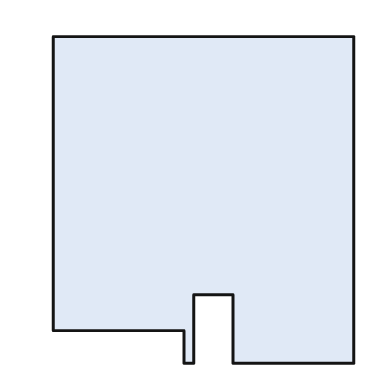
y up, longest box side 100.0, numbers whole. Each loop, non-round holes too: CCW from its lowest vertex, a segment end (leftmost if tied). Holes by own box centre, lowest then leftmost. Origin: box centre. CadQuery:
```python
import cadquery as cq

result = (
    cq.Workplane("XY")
    .moveTo(-6.0, -50.0)
    .lineTo(-3.0, -50.0)
    .lineTo(-3.0, -29.0)
    .lineTo(9.0, -29.0)
    .lineTo(9.0, -50.0)
    .lineTo(46.0, -50.0)
    .lineTo(46.0, 50.0)
    .lineTo(-46.0, 50.0)
    .lineTo(-46.0, -40.0)
    .lineTo(-6.0, -40.0)
    .close()
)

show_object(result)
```